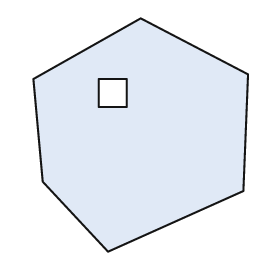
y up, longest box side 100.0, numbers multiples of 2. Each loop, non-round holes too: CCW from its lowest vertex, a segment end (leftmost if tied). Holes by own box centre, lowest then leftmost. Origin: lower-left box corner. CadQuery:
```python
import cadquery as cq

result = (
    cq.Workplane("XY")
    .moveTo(32.0, 0.0)
    .lineTo(90.0, 26.0)
    .lineTo(92.0, 76.0)
    .lineTo(46.0, 100.0)
    .lineTo(0.0, 74.0)
    .lineTo(4.0, 30.0)
    .close()
    .moveTo(28.0, 62.0)
    .lineTo(40.0, 62.0)
    .lineTo(40.0, 74.0)
    .lineTo(28.0, 74.0)
    .close()
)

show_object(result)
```